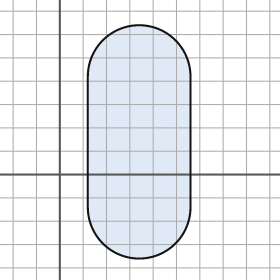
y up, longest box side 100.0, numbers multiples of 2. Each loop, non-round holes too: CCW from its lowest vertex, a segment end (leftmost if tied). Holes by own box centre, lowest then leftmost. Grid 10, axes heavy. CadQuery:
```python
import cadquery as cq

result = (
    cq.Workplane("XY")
    .moveTo(12.0, -14.0)
    .threePointArc((34.0, -36.0), (56.0, -14.0))
    .lineTo(56.0, 42.0)
    .threePointArc((34.0, 64.0), (12.0, 42.0))
    .close()
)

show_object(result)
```